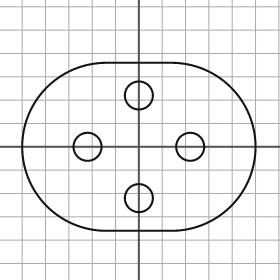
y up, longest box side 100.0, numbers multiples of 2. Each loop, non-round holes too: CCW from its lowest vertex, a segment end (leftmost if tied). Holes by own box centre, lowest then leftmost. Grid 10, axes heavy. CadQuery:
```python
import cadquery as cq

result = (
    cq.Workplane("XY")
    .moveTo(-14.0, -36.0)
    .lineTo(14.0, -36.0)
    .threePointArc((50.0, 0.0), (14.0, 36.0))
    .lineTo(-14.0, 36.0)
    .threePointArc((-50.0, 0.0), (-14.0, -36.0))
    .close()
    .moveTo(0.0, -22.0)
    .circle(6.0)
    .moveTo(-22.0, 0.0)
    .circle(6.0)
    .moveTo(22.0, 0.0)
    .circle(6.0)
    .moveTo(0.0, 22.0)
    .circle(6.0)
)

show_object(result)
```